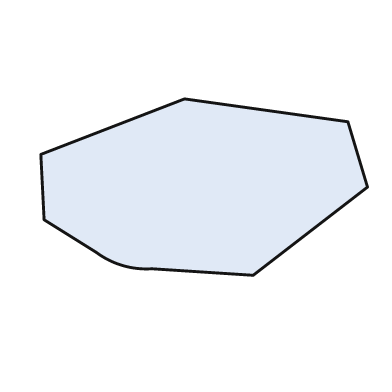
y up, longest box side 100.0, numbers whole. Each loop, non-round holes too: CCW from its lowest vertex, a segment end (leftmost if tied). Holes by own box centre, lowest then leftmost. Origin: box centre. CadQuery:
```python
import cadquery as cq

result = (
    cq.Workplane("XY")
    .moveTo(15.0, -27.0)
    .lineTo(50.0, 0.0)
    .lineTo(44.0, 20.0)
    .lineTo(-6.0, 27.0)
    .lineTo(-50.0, 10.0)
    .lineTo(-49.0, -10.0)
    .lineTo(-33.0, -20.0)
    .threePointArc((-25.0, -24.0), (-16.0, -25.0))
    .close()
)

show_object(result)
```